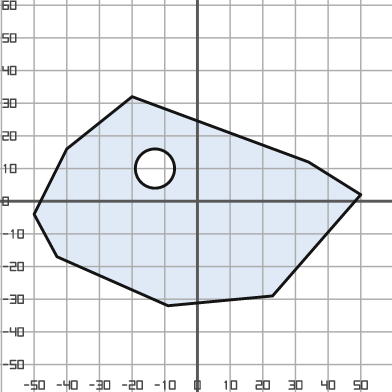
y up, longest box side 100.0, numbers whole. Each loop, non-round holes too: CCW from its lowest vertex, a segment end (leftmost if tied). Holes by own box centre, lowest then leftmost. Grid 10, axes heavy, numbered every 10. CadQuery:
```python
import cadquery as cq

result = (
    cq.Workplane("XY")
    .moveTo(-9.0, -32.0)
    .lineTo(23.0, -29.0)
    .lineTo(50.0, 2.0)
    .lineTo(34.0, 12.0)
    .lineTo(-20.0, 32.0)
    .lineTo(-40.0, 16.0)
    .lineTo(-50.0, -4.0)
    .lineTo(-43.0, -17.0)
    .close()
    .moveTo(-13.0, 10.0)
    .circle(6.0)
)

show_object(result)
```